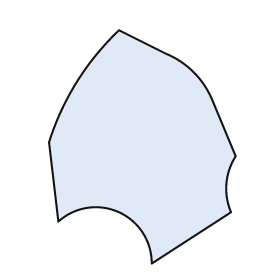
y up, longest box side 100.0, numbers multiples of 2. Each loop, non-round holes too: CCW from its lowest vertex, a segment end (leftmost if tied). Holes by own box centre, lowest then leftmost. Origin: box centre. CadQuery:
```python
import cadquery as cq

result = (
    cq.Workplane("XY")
    .moveTo(4.0, -50.0)
    .lineTo(38.0, -28.0)
    .threePointArc((36.0, -16.0), (40.0, -4.0))
    .lineTo(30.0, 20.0)
    .threePointArc((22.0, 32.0), (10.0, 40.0))
    .lineTo(-10.0, 50.0)
    .threePointArc((-28.0, 28.0), (-40.0, 2.0))
    .lineTo(-36.0, -32.0)
    .threePointArc((-10.0, -28.0), (4.0, -50.0))
    .close()
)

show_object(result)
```